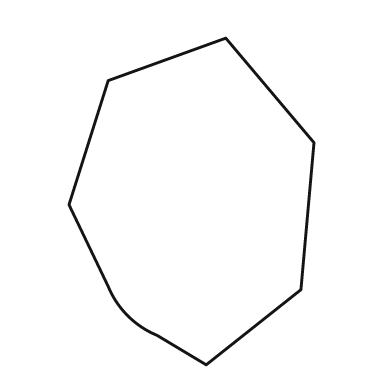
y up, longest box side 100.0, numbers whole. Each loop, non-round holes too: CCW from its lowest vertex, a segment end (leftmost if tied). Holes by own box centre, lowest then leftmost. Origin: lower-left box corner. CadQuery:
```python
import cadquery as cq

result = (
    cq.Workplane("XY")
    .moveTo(42.0, 0.0)
    .lineTo(71.0, 23.0)
    .lineTo(75.0, 68.0)
    .lineTo(48.0, 100.0)
    .lineTo(12.0, 87.0)
    .lineTo(0.0, 49.0)
    .lineTo(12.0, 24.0)
    .threePointArc((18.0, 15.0), (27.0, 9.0))
    .close()
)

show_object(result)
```